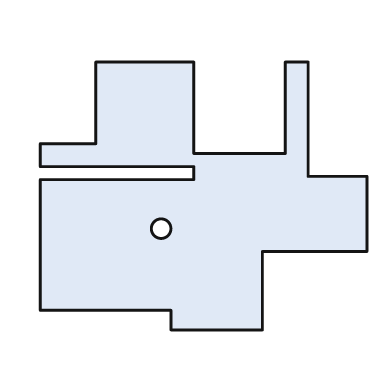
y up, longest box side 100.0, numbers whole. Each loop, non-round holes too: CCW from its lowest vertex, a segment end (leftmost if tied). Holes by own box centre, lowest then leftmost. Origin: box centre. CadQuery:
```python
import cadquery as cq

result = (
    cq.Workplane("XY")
    .moveTo(-10.0, -41.0)
    .lineTo(18.0, -41.0)
    .lineTo(18.0, -17.0)
    .lineTo(50.0, -17.0)
    .lineTo(50.0, 6.0)
    .lineTo(32.0, 6.0)
    .lineTo(32.0, 41.0)
    .lineTo(25.0, 41.0)
    .lineTo(25.0, 13.0)
    .lineTo(-3.0, 13.0)
    .lineTo(-3.0, 41.0)
    .lineTo(-33.0, 41.0)
    .lineTo(-33.0, 16.0)
    .lineTo(-50.0, 16.0)
    .lineTo(-50.0, 9.0)
    .lineTo(-3.0, 9.0)
    .lineTo(-3.0, 5.0)
    .lineTo(-50.0, 5.0)
    .lineTo(-50.0, -35.0)
    .lineTo(-10.0, -35.0)
    .close()
    .moveTo(-13.0, -10.0)
    .circle(3.0)
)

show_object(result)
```